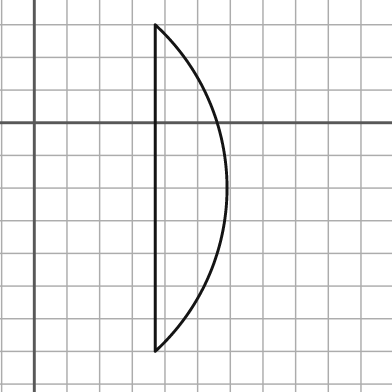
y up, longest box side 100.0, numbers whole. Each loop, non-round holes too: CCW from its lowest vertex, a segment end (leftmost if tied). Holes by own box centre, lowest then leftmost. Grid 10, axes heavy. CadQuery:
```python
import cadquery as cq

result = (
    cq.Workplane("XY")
    .moveTo(37.0, -70.0)
    .threePointArc((59.0, -20.0), (37.0, 30.0))
    .close()
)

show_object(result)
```